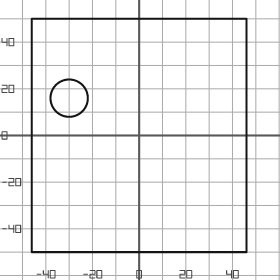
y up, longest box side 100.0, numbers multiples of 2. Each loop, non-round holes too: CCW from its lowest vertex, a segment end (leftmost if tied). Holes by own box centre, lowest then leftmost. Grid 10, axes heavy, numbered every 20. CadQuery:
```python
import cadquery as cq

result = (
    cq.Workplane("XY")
    .moveTo(-46.0, -50.0)
    .lineTo(46.0, -50.0)
    .lineTo(46.0, 50.0)
    .lineTo(-46.0, 50.0)
    .close()
    .moveTo(-30.0, 16.0)
    .circle(8.0)
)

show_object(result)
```